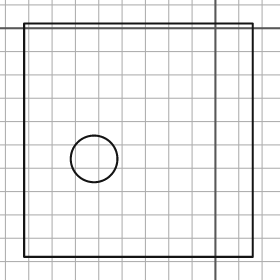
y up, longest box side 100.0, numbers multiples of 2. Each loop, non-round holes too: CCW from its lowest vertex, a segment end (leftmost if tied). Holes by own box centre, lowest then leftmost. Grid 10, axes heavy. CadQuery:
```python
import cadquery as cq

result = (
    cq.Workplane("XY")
    .moveTo(-82.0, -98.0)
    .lineTo(16.0, -98.0)
    .lineTo(16.0, 2.0)
    .lineTo(-82.0, 2.0)
    .close()
    .moveTo(-52.0, -56.0)
    .circle(10.0)
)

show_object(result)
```